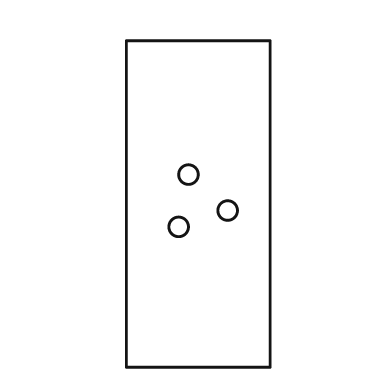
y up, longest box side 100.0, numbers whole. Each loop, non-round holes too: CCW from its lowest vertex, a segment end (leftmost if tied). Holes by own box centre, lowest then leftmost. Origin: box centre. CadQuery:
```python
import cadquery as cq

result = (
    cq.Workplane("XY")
    .moveTo(-22.0, -50.0)
    .lineTo(22.0, -50.0)
    .lineTo(22.0, 50.0)
    .lineTo(-22.0, 50.0)
    .close()
    .moveTo(-6.0, -7.0)
    .circle(3.0)
    .moveTo(9.0, -2.0)
    .circle(3.0)
    .moveTo(-3.0, 9.0)
    .circle(3.0)
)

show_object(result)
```